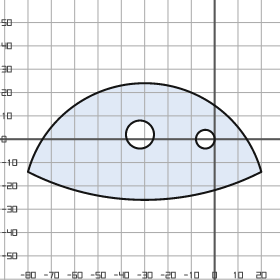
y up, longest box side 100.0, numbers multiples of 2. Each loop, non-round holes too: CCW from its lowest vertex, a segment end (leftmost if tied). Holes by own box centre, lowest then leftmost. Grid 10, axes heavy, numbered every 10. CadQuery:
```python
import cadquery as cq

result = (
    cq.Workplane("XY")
    .moveTo(-80.0, -14.0)
    .threePointArc((-30.0, -26.0), (20.0, -14.0))
    .threePointArc((-30.0, 24.0), (-80.0, -14.0))
    .close()
    .moveTo(-4.0, 0.0)
    .circle(4.0)
    .moveTo(-32.0, 2.0)
    .circle(6.0)
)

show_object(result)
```